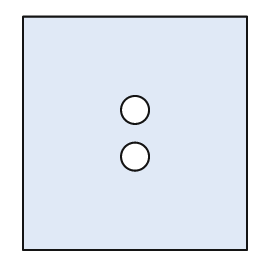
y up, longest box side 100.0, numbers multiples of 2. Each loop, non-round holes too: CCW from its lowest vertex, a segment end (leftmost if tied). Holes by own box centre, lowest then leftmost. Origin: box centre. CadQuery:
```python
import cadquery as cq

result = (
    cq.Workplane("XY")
    .moveTo(-48.0, -50.0)
    .lineTo(48.0, -50.0)
    .lineTo(48.0, 50.0)
    .lineTo(-48.0, 50.0)
    .close()
    .moveTo(0.0, -10.0)
    .circle(6.0)
    .moveTo(0.0, 10.0)
    .circle(6.0)
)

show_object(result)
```